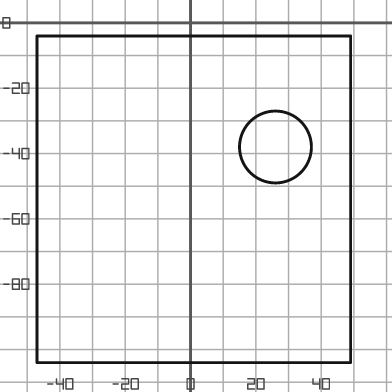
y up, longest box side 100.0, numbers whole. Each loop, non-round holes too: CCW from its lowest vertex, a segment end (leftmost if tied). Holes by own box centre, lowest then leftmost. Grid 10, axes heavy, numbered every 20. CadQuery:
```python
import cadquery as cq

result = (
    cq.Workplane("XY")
    .moveTo(-47.0, -104.0)
    .lineTo(49.0, -104.0)
    .lineTo(49.0, -4.0)
    .lineTo(-47.0, -4.0)
    .close()
    .moveTo(26.0, -38.0)
    .circle(11.0)
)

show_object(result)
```